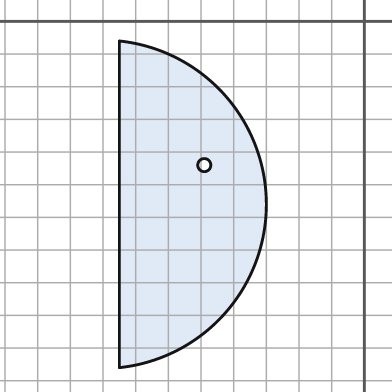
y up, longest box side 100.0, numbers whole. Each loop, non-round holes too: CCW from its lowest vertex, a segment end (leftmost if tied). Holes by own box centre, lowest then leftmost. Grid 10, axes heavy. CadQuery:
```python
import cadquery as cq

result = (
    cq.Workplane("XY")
    .moveTo(-75.0, -106.0)
    .threePointArc((-30.0, -56.0), (-75.0, -6.0))
    .close()
    .moveTo(-49.0, -44.0)
    .circle(2.0)
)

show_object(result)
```